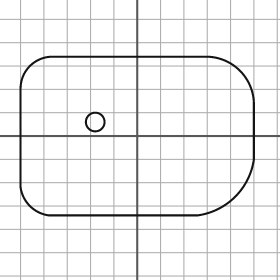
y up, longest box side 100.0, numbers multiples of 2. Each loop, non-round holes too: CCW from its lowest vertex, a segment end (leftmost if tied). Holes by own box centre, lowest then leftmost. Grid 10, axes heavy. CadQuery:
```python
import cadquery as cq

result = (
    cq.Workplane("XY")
    .moveTo(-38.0, -34.0)
    .lineTo(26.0, -34.0)
    .threePointArc((42.0, -26.0), (50.0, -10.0))
    .lineTo(50.0, 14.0)
    .threePointArc((44.0, 28.0), (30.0, 34.0))
    .lineTo(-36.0, 34.0)
    .threePointArc((-46.0, 30.0), (-50.0, 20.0))
    .lineTo(-50.0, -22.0)
    .threePointArc((-46.0, -30.0), (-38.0, -34.0))
    .close()
    .moveTo(-18.0, 6.0)
    .circle(4.0)
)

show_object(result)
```